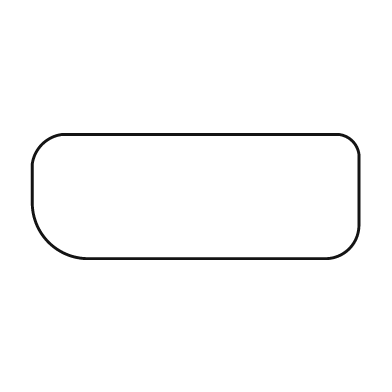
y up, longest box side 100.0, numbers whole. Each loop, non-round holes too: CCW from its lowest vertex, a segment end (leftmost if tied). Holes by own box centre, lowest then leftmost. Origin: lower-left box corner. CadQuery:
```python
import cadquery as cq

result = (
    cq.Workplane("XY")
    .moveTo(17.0, 0.0)
    .lineTo(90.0, 0.0)
    .threePointArc((97.0, 3.0), (100.0, 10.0))
    .lineTo(100.0, 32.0)
    .threePointArc((98.0, 36.0), (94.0, 38.0))
    .lineTo(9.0, 38.0)
    .threePointArc((3.0, 35.0), (0.0, 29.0))
    .lineTo(0.0, 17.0)
    .threePointArc((5.0, 5.0), (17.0, 0.0))
    .close()
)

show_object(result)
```